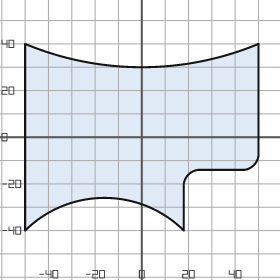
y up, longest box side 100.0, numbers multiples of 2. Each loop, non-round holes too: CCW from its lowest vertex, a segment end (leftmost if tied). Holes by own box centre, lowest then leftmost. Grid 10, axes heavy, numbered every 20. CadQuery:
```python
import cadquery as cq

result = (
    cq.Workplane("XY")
    .moveTo(-50.0, -40.0)
    .threePointArc((-16.0, -26.0), (18.0, -40.0))
    .lineTo(18.0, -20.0)
    .threePointArc((20.0, -16.0), (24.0, -14.0))
    .lineTo(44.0, -14.0)
    .threePointArc((48.0, -12.0), (50.0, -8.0))
    .lineTo(50.0, 40.0)
    .threePointArc((0.0, 30.0), (-50.0, 40.0))
    .close()
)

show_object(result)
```